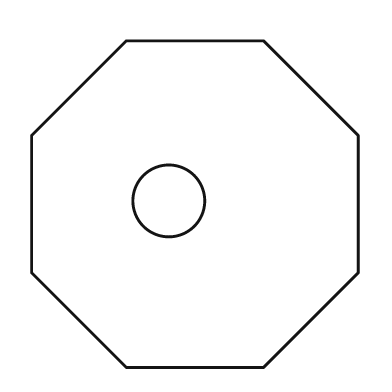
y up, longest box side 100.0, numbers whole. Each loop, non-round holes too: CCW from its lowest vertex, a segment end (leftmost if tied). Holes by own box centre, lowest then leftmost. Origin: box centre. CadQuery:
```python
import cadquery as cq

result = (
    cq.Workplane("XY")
    .moveTo(-21.0, -50.0)
    .lineTo(21.0, -50.0)
    .lineTo(50.0, -21.0)
    .lineTo(50.0, 21.0)
    .lineTo(21.0, 50.0)
    .lineTo(-21.0, 50.0)
    .lineTo(-50.0, 21.0)
    .lineTo(-50.0, -21.0)
    .close()
    .moveTo(-8.0, 1.0)
    .circle(11.0)
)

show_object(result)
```